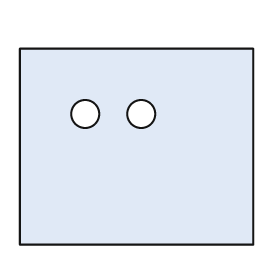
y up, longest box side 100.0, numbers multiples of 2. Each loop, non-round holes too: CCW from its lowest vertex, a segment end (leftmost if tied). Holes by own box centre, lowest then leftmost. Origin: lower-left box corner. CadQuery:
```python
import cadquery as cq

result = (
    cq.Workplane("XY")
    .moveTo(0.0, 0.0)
    .lineTo(100.0, 0.0)
    .lineTo(100.0, 84.0)
    .lineTo(0.0, 84.0)
    .close()
    .moveTo(28.0, 56.0)
    .circle(6.0)
    .moveTo(52.0, 56.0)
    .circle(6.0)
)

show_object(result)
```